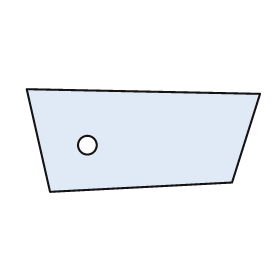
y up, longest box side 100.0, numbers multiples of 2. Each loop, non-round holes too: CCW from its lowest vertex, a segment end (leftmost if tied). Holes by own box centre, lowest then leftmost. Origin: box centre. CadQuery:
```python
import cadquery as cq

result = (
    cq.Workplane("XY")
    .moveTo(-40.0, -22.0)
    .lineTo(38.0, -18.0)
    .lineTo(50.0, 20.0)
    .lineTo(-50.0, 22.0)
    .close()
    .moveTo(-24.0, -2.0)
    .circle(4.0)
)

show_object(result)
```